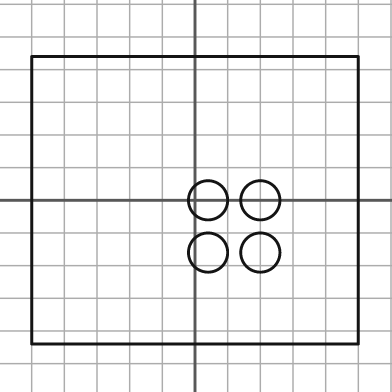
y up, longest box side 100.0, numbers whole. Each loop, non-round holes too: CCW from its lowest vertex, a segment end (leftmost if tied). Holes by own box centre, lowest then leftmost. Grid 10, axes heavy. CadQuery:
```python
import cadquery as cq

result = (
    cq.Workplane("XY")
    .moveTo(-50.0, -44.0)
    .lineTo(50.0, -44.0)
    .lineTo(50.0, 44.0)
    .lineTo(-50.0, 44.0)
    .close()
    .moveTo(4.0, -16.0)
    .circle(6.0)
    .moveTo(20.0, -16.0)
    .circle(6.0)
    .moveTo(4.0, 0.0)
    .circle(6.0)
    .moveTo(20.0, 0.0)
    .circle(6.0)
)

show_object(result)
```